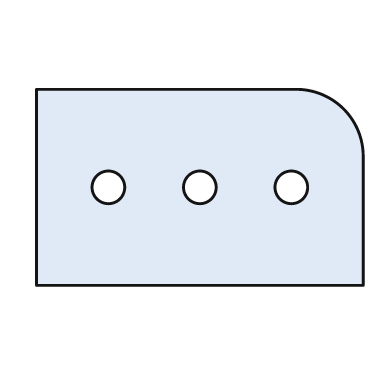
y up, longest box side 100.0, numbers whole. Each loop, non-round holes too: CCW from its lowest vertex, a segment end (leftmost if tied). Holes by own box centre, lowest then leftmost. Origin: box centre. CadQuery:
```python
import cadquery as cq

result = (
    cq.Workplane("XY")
    .moveTo(-50.0, -30.0)
    .lineTo(50.0, -30.0)
    .lineTo(50.0, 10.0)
    .threePointArc((44.0, 24.0), (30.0, 30.0))
    .lineTo(-50.0, 30.0)
    .close()
    .moveTo(-28.0, 0.0)
    .circle(5.0)
    .moveTo(0.0, 0.0)
    .circle(5.0)
    .moveTo(28.0, 0.0)
    .circle(5.0)
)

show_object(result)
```